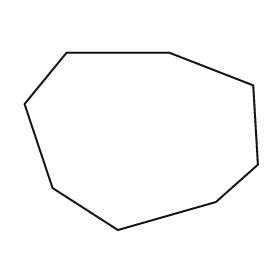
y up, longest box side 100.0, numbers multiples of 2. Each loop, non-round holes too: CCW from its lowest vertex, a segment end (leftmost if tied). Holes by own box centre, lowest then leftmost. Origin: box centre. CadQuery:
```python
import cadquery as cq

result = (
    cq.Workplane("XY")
    .moveTo(-10.0, -38.0)
    .lineTo(32.0, -26.0)
    .lineTo(50.0, -10.0)
    .lineTo(48.0, 24.0)
    .lineTo(12.0, 38.0)
    .lineTo(-32.0, 38.0)
    .lineTo(-50.0, 16.0)
    .lineTo(-38.0, -20.0)
    .close()
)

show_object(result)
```